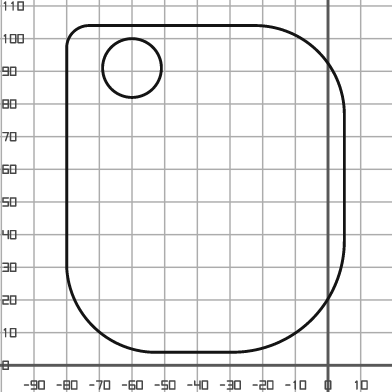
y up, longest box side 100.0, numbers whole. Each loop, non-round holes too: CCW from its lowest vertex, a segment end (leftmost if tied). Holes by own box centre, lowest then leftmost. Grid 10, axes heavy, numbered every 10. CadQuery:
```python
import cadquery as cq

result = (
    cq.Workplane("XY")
    .moveTo(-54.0, 4.0)
    .lineTo(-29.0, 4.0)
    .threePointArc((-5.0, 14.0), (5.0, 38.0))
    .lineTo(5.0, 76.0)
    .threePointArc((-3.0, 96.0), (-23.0, 104.0))
    .lineTo(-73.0, 104.0)
    .threePointArc((-78.0, 102.0), (-80.0, 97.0))
    .lineTo(-80.0, 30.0)
    .threePointArc((-72.0, 12.0), (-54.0, 4.0))
    .close()
    .moveTo(-60.0, 91.0)
    .circle(9.0)
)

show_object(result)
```